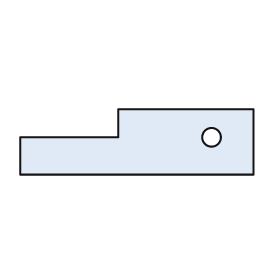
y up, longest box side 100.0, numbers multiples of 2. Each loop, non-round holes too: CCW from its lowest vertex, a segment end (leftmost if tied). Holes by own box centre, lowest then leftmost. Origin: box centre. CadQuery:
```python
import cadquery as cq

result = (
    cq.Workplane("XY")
    .moveTo(-50.0, -14.0)
    .lineTo(50.0, -14.0)
    .lineTo(50.0, 14.0)
    .lineTo(-8.0, 14.0)
    .lineTo(-8.0, 2.0)
    .lineTo(-50.0, 2.0)
    .close()
    .moveTo(32.0, 2.0)
    .circle(4.0)
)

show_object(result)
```